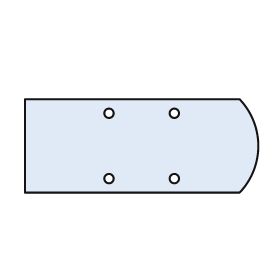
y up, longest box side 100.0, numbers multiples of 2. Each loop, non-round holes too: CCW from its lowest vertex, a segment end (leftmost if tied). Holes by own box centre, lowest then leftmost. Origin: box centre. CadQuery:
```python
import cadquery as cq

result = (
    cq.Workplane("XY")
    .moveTo(-50.0, -20.0)
    .lineTo(42.0, -20.0)
    .threePointArc((50.0, 0.0), (42.0, 20.0))
    .lineTo(-50.0, 20.0)
    .close()
    .moveTo(-14.0, -14.0)
    .circle(2.0)
    .moveTo(14.0, -14.0)
    .circle(2.0)
    .moveTo(-14.0, 14.0)
    .circle(2.0)
    .moveTo(14.0, 14.0)
    .circle(2.0)
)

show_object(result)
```